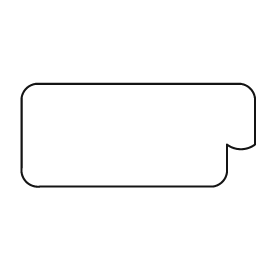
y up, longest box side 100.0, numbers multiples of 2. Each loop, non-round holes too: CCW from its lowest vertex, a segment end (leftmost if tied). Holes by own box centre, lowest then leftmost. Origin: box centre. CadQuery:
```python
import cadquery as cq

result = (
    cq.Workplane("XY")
    .moveTo(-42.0, -22.0)
    .lineTo(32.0, -22.0)
    .threePointArc((36.0, -20.0), (38.0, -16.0))
    .lineTo(38.0, -4.0)
    .threePointArc((44.0, -6.0), (50.0, -4.0))
    .lineTo(50.0, 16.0)
    .threePointArc((48.0, 20.0), (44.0, 22.0))
    .lineTo(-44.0, 22.0)
    .threePointArc((-48.0, 20.0), (-50.0, 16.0))
    .lineTo(-50.0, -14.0)
    .threePointArc((-48.0, -20.0), (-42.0, -22.0))
    .close()
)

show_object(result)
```